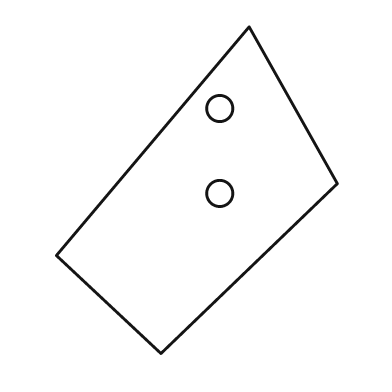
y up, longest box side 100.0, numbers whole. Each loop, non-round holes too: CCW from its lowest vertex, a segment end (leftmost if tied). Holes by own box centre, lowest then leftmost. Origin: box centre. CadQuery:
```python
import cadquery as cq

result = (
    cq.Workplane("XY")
    .moveTo(-11.0, -50.0)
    .lineTo(43.0, 2.0)
    .lineTo(16.0, 50.0)
    .lineTo(-43.0, -20.0)
    .close()
    .moveTo(7.0, -1.0)
    .circle(4.0)
    .moveTo(7.0, 25.0)
    .circle(4.0)
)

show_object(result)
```